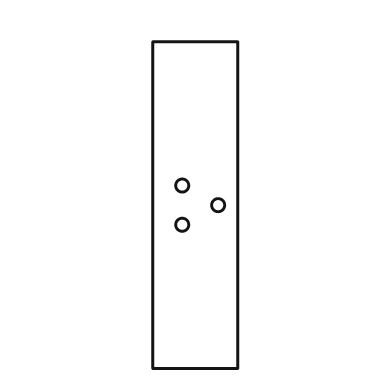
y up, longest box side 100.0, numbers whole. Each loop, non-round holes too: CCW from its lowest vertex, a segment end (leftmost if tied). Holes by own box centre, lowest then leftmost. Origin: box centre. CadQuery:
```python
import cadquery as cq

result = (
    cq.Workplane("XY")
    .moveTo(-13.0, -50.0)
    .lineTo(13.0, -50.0)
    .lineTo(13.0, 50.0)
    .lineTo(-13.0, 50.0)
    .close()
    .moveTo(-4.0, -6.0)
    .circle(2.0)
    .moveTo(7.0, 0.0)
    .circle(2.0)
    .moveTo(-4.0, 6.0)
    .circle(2.0)
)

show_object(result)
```